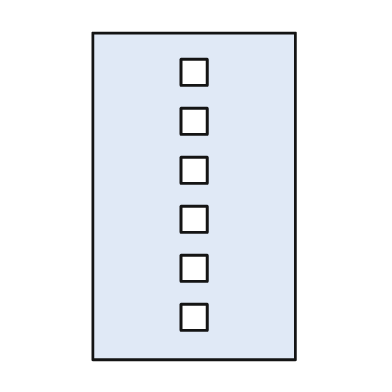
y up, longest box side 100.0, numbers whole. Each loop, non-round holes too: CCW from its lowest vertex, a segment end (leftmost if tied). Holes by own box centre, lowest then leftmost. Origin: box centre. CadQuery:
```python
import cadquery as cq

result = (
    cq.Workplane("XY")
    .moveTo(-31.0, -50.0)
    .lineTo(31.0, -50.0)
    .lineTo(31.0, 50.0)
    .lineTo(-31.0, 50.0)
    .close()
    .moveTo(-4.0, -41.0)
    .lineTo(4.0, -41.0)
    .lineTo(4.0, -33.0)
    .lineTo(-4.0, -33.0)
    .close()
    .moveTo(-4.0, -26.0)
    .lineTo(4.0, -26.0)
    .lineTo(4.0, -18.0)
    .lineTo(-4.0, -18.0)
    .close()
    .moveTo(-4.0, -11.0)
    .lineTo(4.0, -11.0)
    .lineTo(4.0, -3.0)
    .lineTo(-4.0, -3.0)
    .close()
    .moveTo(-4.0, 4.0)
    .lineTo(4.0, 4.0)
    .lineTo(4.0, 12.0)
    .lineTo(-4.0, 12.0)
    .close()
    .moveTo(-4.0, 19.0)
    .lineTo(4.0, 19.0)
    .lineTo(4.0, 27.0)
    .lineTo(-4.0, 27.0)
    .close()
    .moveTo(-4.0, 34.0)
    .lineTo(4.0, 34.0)
    .lineTo(4.0, 42.0)
    .lineTo(-4.0, 42.0)
    .close()
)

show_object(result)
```